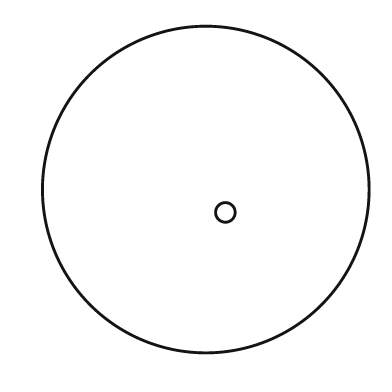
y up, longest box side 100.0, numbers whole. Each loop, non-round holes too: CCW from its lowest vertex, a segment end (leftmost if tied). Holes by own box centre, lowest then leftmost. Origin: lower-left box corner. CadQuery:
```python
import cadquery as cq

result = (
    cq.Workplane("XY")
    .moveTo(50.0, 50.0)
    .circle(50.0)
    .moveTo(56.0, 43.0)
    .circle(3.0)
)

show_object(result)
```